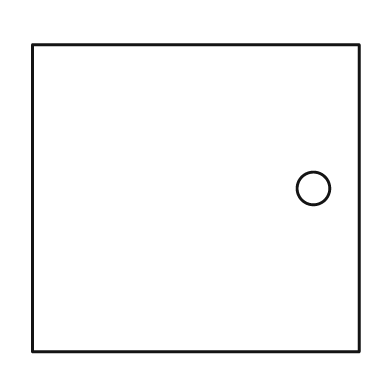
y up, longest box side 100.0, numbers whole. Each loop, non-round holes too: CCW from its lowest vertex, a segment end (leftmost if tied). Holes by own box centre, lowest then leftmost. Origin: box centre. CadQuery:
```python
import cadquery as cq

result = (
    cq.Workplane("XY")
    .moveTo(-50.0, -47.0)
    .lineTo(50.0, -47.0)
    .lineTo(50.0, 47.0)
    .lineTo(-50.0, 47.0)
    .close()
    .moveTo(36.0, 3.0)
    .circle(5.0)
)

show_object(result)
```